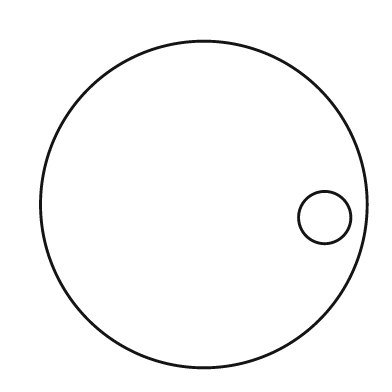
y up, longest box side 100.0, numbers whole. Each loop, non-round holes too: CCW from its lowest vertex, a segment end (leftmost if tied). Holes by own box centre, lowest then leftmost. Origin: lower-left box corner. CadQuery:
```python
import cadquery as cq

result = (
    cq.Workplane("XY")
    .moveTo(50.0, 50.0)
    .circle(50.0)
    .moveTo(87.0, 46.0)
    .circle(8.0)
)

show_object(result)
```